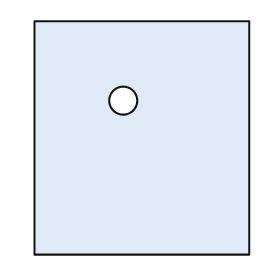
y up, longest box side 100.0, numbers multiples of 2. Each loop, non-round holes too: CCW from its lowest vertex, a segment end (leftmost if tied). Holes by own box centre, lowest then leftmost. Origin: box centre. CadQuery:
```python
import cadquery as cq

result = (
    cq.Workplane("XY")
    .moveTo(-46.0, -50.0)
    .lineTo(46.0, -50.0)
    .lineTo(46.0, 50.0)
    .lineTo(-46.0, 50.0)
    .close()
    .moveTo(-8.0, 16.0)
    .circle(6.0)
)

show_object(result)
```